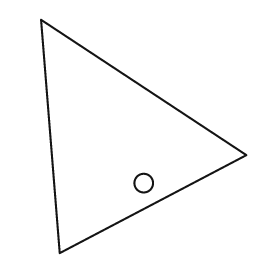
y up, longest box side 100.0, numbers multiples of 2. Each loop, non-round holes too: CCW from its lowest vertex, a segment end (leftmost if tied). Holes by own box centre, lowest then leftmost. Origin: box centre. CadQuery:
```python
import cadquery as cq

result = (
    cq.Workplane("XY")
    .moveTo(-36.0, -50.0)
    .lineTo(44.0, -8.0)
    .lineTo(-44.0, 50.0)
    .close()
    .moveTo(0.0, -20.0)
    .circle(4.0)
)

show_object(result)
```